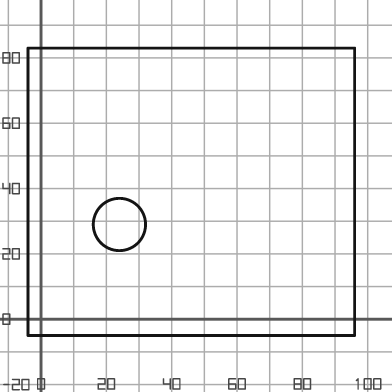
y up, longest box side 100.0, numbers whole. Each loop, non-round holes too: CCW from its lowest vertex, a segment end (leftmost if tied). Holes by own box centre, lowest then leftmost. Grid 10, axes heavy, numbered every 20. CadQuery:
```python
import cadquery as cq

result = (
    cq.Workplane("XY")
    .moveTo(-4.0, -5.0)
    .lineTo(96.0, -5.0)
    .lineTo(96.0, 83.0)
    .lineTo(-4.0, 83.0)
    .close()
    .moveTo(24.0, 29.0)
    .circle(8.0)
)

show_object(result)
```